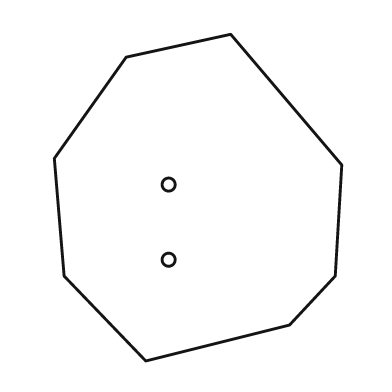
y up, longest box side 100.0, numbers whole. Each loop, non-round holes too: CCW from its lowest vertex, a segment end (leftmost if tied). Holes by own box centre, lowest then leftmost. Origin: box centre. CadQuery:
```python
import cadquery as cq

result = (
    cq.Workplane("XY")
    .moveTo(-16.0, -50.0)
    .lineTo(28.0, -39.0)
    .lineTo(42.0, -24.0)
    .lineTo(44.0, 10.0)
    .lineTo(10.0, 50.0)
    .lineTo(-22.0, 43.0)
    .lineTo(-44.0, 12.0)
    .lineTo(-41.0, -24.0)
    .close()
    .moveTo(-9.0, -19.0)
    .circle(2.0)
    .moveTo(-9.0, 4.0)
    .circle(2.0)
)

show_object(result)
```